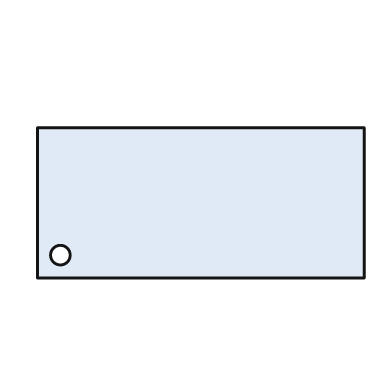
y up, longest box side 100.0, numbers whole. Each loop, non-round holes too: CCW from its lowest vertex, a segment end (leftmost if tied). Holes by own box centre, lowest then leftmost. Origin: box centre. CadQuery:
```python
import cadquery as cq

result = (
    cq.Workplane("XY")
    .moveTo(-50.0, -23.0)
    .lineTo(50.0, -23.0)
    .lineTo(50.0, 23.0)
    .lineTo(-50.0, 23.0)
    .close()
    .moveTo(-43.0, -16.0)
    .circle(3.0)
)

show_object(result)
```